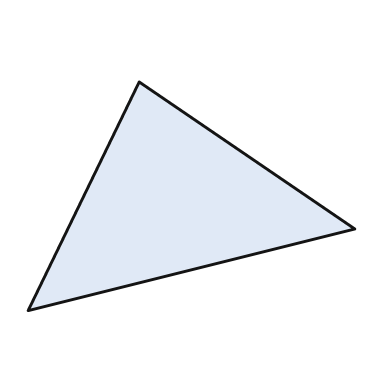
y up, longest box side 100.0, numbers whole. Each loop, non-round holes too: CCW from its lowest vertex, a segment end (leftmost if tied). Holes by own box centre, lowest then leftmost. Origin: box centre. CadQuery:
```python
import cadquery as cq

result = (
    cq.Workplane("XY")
    .moveTo(-50.0, -35.0)
    .lineTo(50.0, -10.0)
    .lineTo(-16.0, 35.0)
    .close()
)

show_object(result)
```